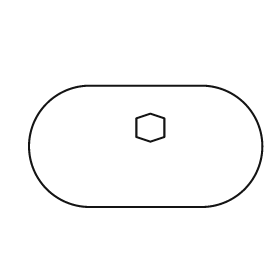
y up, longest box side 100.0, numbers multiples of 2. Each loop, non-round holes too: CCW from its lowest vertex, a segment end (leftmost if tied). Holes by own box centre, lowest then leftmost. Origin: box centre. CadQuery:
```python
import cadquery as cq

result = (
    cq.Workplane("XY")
    .moveTo(-24.0, -26.0)
    .lineTo(24.0, -26.0)
    .threePointArc((50.0, 0.0), (24.0, 26.0))
    .lineTo(-24.0, 26.0)
    .threePointArc((-50.0, 0.0), (-24.0, -26.0))
    .close()
    .moveTo(2.0, 2.0)
    .lineTo(8.0, 4.0)
    .lineTo(8.0, 12.0)
    .lineTo(2.0, 14.0)
    .lineTo(-4.0, 12.0)
    .lineTo(-4.0, 4.0)
    .close()
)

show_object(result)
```